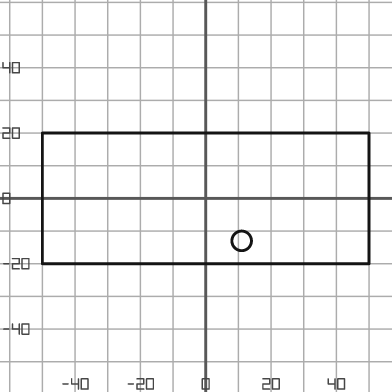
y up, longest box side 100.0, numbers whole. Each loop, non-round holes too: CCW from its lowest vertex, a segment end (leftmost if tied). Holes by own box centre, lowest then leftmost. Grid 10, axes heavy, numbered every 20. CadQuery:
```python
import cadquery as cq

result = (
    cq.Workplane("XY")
    .moveTo(-50.0, -20.0)
    .lineTo(50.0, -20.0)
    .lineTo(50.0, 20.0)
    .lineTo(-50.0, 20.0)
    .close()
    .moveTo(11.0, -13.0)
    .circle(3.0)
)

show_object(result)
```